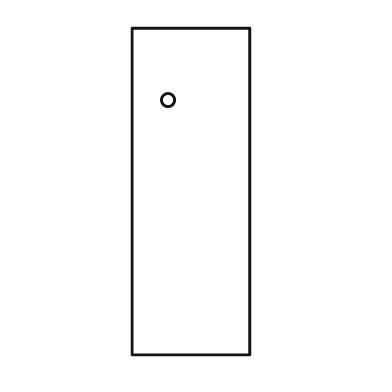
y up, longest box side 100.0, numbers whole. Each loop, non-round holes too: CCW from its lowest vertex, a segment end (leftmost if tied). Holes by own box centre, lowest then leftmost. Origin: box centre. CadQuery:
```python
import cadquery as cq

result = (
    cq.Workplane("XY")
    .moveTo(-18.0, -50.0)
    .lineTo(18.0, -50.0)
    .lineTo(18.0, 50.0)
    .lineTo(-18.0, 50.0)
    .close()
    .moveTo(-7.0, 28.0)
    .circle(2.0)
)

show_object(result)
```